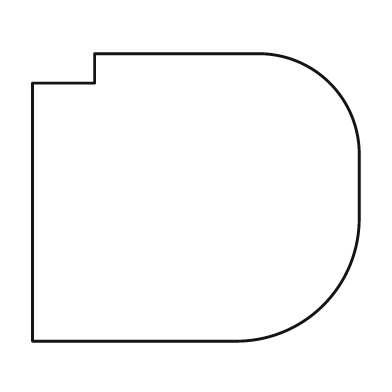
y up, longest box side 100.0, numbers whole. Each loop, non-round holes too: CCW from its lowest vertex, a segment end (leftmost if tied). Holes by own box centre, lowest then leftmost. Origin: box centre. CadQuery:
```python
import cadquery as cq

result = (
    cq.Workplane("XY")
    .moveTo(-50.0, -44.0)
    .lineTo(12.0, -44.0)
    .threePointArc((39.0, -33.0), (50.0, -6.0))
    .lineTo(50.0, 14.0)
    .threePointArc((41.0, 35.0), (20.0, 44.0))
    .lineTo(-31.0, 44.0)
    .lineTo(-31.0, 35.0)
    .lineTo(-50.0, 35.0)
    .close()
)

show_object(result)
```